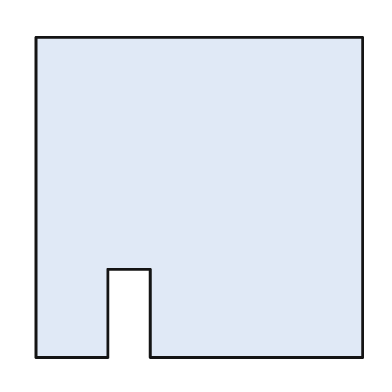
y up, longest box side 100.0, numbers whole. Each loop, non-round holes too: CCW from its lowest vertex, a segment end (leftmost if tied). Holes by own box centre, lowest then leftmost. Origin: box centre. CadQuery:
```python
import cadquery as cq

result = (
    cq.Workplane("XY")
    .moveTo(-50.0, -49.0)
    .lineTo(-28.0, -49.0)
    .lineTo(-28.0, -22.0)
    .lineTo(-15.0, -22.0)
    .lineTo(-15.0, -49.0)
    .lineTo(50.0, -49.0)
    .lineTo(50.0, 49.0)
    .lineTo(-50.0, 49.0)
    .close()
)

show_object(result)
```